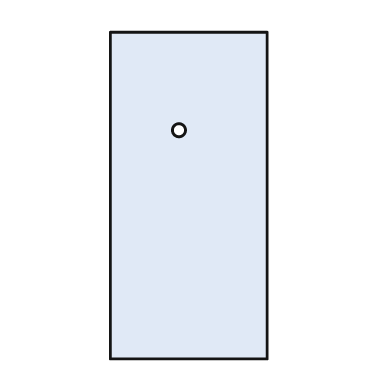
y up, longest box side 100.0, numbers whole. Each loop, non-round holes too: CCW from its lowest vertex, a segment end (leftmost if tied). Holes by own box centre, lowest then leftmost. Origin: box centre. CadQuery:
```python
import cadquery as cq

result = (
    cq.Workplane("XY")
    .moveTo(-24.0, -50.0)
    .lineTo(24.0, -50.0)
    .lineTo(24.0, 50.0)
    .lineTo(-24.0, 50.0)
    .close()
    .moveTo(-3.0, 20.0)
    .circle(2.0)
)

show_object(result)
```